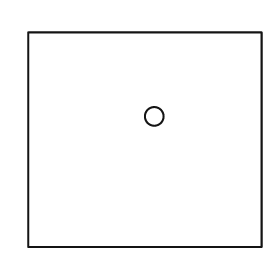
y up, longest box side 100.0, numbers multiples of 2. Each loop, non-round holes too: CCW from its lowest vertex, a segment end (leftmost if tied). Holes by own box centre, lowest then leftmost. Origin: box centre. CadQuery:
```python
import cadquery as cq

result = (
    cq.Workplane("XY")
    .moveTo(-50.0, -46.0)
    .lineTo(50.0, -46.0)
    .lineTo(50.0, 46.0)
    .lineTo(-50.0, 46.0)
    .close()
    .moveTo(4.0, 10.0)
    .circle(4.0)
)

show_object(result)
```